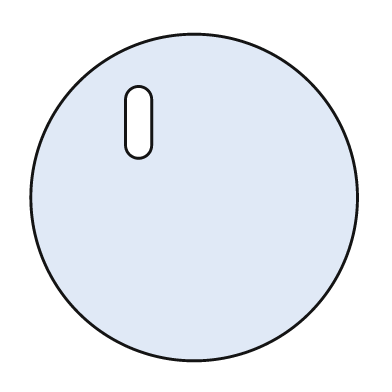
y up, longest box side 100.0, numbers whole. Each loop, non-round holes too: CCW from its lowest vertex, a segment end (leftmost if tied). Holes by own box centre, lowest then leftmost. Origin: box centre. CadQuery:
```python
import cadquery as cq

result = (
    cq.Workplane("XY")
    .moveTo(0.0, 0.0)
    .circle(50.0)
    .moveTo(-21.0, 16.0)
    .threePointArc((-17.0, 12.0), (-13.0, 16.0))
    .lineTo(-13.0, 30.0)
    .threePointArc((-17.0, 34.0), (-21.0, 30.0))
    .close()
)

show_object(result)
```